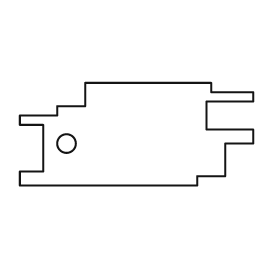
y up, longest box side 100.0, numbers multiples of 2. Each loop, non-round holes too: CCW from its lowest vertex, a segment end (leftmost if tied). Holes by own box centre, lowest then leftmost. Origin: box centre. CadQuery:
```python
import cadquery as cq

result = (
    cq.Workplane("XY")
    .moveTo(-50.0, -22.0)
    .lineTo(26.0, -22.0)
    .lineTo(26.0, -18.0)
    .lineTo(38.0, -18.0)
    .lineTo(38.0, -4.0)
    .lineTo(50.0, -4.0)
    .lineTo(50.0, 2.0)
    .lineTo(30.0, 2.0)
    .lineTo(30.0, 14.0)
    .lineTo(50.0, 14.0)
    .lineTo(50.0, 18.0)
    .lineTo(32.0, 18.0)
    .lineTo(32.0, 22.0)
    .lineTo(-22.0, 22.0)
    .lineTo(-22.0, 12.0)
    .lineTo(-34.0, 12.0)
    .lineTo(-34.0, 8.0)
    .lineTo(-50.0, 8.0)
    .lineTo(-50.0, 4.0)
    .lineTo(-40.0, 4.0)
    .lineTo(-40.0, -16.0)
    .lineTo(-50.0, -16.0)
    .close()
    .moveTo(-30.0, -4.0)
    .circle(4.0)
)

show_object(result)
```